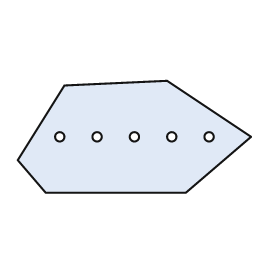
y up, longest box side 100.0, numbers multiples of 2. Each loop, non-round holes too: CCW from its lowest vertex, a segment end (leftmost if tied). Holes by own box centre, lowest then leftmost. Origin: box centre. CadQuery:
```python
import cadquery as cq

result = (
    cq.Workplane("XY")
    .moveTo(-38.0, -24.0)
    .lineTo(22.0, -24.0)
    .lineTo(50.0, 0.0)
    .lineTo(14.0, 24.0)
    .lineTo(-30.0, 22.0)
    .lineTo(-50.0, -10.0)
    .close()
    .moveTo(-32.0, 0.0)
    .circle(2.0)
    .moveTo(-16.0, 0.0)
    .circle(2.0)
    .moveTo(0.0, 0.0)
    .circle(2.0)
    .moveTo(16.0, 0.0)
    .circle(2.0)
    .moveTo(32.0, 0.0)
    .circle(2.0)
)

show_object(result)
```